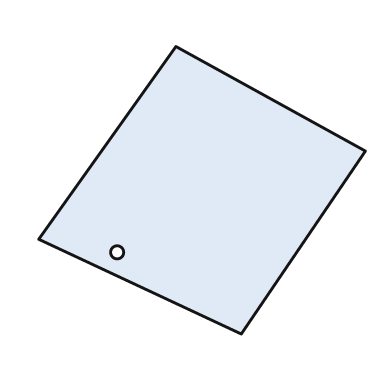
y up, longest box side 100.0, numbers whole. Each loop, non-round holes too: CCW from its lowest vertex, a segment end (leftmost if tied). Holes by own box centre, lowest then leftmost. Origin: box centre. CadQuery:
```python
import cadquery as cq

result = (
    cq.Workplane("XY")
    .moveTo(12.0, -44.0)
    .lineTo(50.0, 12.0)
    .lineTo(-8.0, 44.0)
    .lineTo(-50.0, -15.0)
    .close()
    .moveTo(-26.0, -19.0)
    .circle(2.0)
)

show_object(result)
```